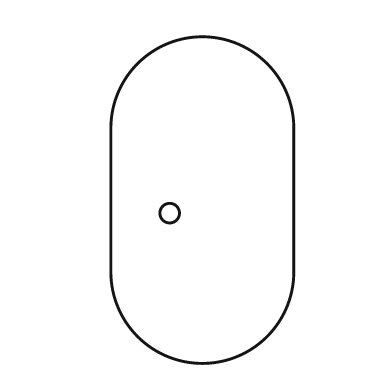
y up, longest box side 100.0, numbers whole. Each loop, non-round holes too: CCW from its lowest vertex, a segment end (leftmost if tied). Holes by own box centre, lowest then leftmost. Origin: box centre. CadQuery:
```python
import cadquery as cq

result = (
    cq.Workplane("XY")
    .moveTo(-28.0, -22.0)
    .threePointArc((0.0, -50.0), (28.0, -22.0))
    .lineTo(28.0, 22.0)
    .threePointArc((0.0, 50.0), (-28.0, 22.0))
    .close()
    .moveTo(-10.0, -4.0)
    .circle(3.0)
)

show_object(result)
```